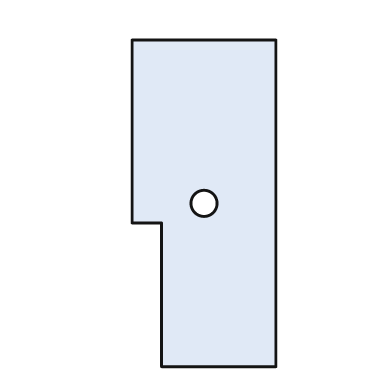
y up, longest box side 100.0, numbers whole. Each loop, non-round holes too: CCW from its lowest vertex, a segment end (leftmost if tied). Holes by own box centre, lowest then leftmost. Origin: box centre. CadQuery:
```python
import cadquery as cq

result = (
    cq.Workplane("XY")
    .moveTo(-13.0, -50.0)
    .lineTo(22.0, -50.0)
    .lineTo(22.0, 50.0)
    .lineTo(-22.0, 50.0)
    .lineTo(-22.0, -6.0)
    .lineTo(-13.0, -6.0)
    .close()
    .moveTo(0.0, 0.0)
    .circle(4.0)
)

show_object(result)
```